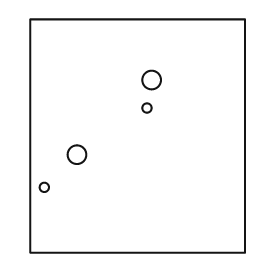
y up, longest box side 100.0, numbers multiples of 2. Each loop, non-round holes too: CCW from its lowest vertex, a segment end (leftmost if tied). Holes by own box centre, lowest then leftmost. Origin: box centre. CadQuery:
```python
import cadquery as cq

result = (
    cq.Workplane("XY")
    .moveTo(-46.0, -50.0)
    .lineTo(46.0, -50.0)
    .lineTo(46.0, 50.0)
    .lineTo(-46.0, 50.0)
    .close()
    .moveTo(-40.0, -22.0)
    .circle(2.0)
    .moveTo(-26.0, -8.0)
    .circle(4.0)
    .moveTo(4.0, 12.0)
    .circle(2.0)
    .moveTo(6.0, 24.0)
    .circle(4.0)
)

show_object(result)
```